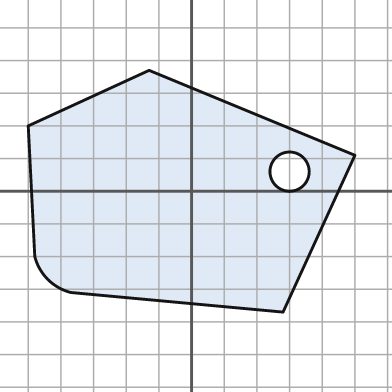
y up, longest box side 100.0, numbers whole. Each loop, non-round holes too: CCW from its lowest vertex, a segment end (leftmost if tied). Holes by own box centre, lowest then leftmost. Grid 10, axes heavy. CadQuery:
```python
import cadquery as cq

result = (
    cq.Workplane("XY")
    .moveTo(28.0, -37.0)
    .lineTo(50.0, 11.0)
    .lineTo(-13.0, 37.0)
    .lineTo(-50.0, 20.0)
    .lineTo(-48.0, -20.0)
    .threePointArc((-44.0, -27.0), (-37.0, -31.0))
    .close()
    .moveTo(30.0, 6.0)
    .circle(6.0)
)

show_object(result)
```